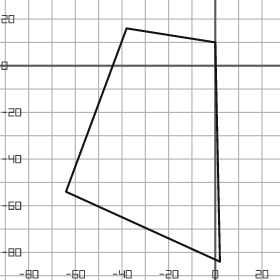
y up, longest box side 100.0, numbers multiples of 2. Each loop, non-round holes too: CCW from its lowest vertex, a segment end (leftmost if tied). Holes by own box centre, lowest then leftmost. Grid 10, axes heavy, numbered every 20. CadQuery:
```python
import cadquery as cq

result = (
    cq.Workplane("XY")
    .moveTo(2.0, -84.0)
    .lineTo(0.0, 10.0)
    .lineTo(-38.0, 16.0)
    .lineTo(-64.0, -54.0)
    .close()
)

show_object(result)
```